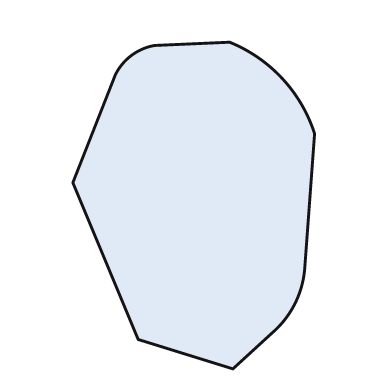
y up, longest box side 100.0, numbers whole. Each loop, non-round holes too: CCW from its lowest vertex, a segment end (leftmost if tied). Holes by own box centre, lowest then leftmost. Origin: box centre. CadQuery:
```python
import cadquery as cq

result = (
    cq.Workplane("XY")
    .moveTo(12.0, -50.0)
    .lineTo(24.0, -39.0)
    .threePointArc((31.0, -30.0), (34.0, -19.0))
    .lineTo(37.0, 22.0)
    .threePointArc((27.0, 39.0), (11.0, 50.0))
    .lineTo(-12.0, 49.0)
    .threePointArc((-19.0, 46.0), (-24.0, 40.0))
    .lineTo(-37.0, 7.0)
    .lineTo(-17.0, -41.0)
    .close()
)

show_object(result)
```